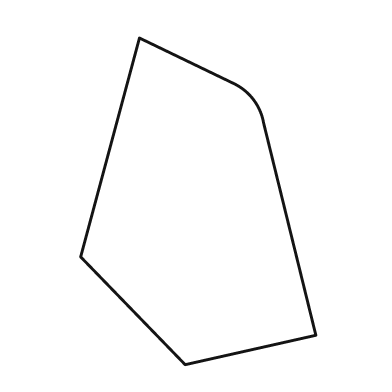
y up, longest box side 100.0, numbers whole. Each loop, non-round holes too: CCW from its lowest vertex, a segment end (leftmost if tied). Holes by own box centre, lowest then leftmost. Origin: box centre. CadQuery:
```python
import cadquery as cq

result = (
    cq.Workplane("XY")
    .moveTo(-4.0, -50.0)
    .lineTo(36.0, -41.0)
    .lineTo(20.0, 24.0)
    .threePointArc((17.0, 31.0), (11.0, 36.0))
    .lineTo(-18.0, 50.0)
    .lineTo(-36.0, -17.0)
    .close()
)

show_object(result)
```